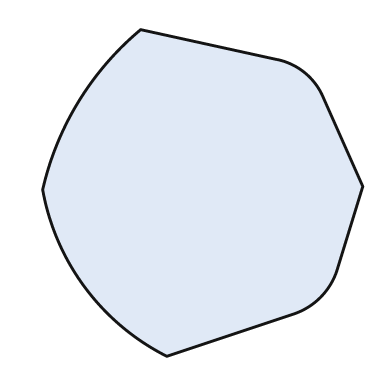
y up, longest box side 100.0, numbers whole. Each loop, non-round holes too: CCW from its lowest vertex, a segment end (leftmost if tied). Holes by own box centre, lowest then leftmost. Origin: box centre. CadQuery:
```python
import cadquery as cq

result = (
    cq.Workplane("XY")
    .moveTo(-11.0, -50.0)
    .lineTo(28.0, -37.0)
    .threePointArc((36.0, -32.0), (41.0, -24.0))
    .lineTo(49.0, 2.0)
    .lineTo(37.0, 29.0)
    .threePointArc((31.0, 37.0), (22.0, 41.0))
    .lineTo(-19.0, 50.0)
    .threePointArc((-38.0, 28.0), (-49.0, 1.0))
    .threePointArc((-36.0, -29.0), (-11.0, -50.0))
    .close()
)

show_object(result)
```